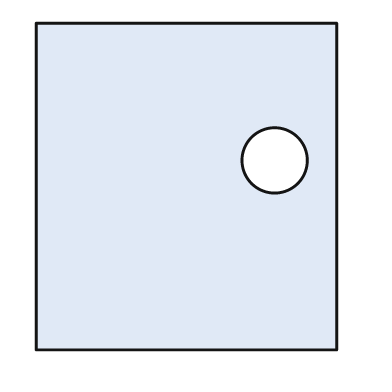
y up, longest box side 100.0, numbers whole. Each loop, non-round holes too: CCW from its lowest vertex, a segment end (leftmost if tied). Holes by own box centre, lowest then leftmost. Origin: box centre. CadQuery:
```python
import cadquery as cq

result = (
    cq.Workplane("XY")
    .moveTo(-46.0, -50.0)
    .lineTo(46.0, -50.0)
    .lineTo(46.0, 50.0)
    .lineTo(-46.0, 50.0)
    .close()
    .moveTo(27.0, 8.0)
    .circle(10.0)
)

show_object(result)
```